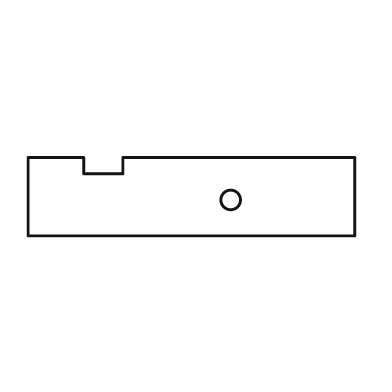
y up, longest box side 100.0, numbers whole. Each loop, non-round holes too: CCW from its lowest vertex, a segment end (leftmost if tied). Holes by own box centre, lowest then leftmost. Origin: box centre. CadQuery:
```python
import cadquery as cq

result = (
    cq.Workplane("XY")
    .moveTo(-50.0, -12.0)
    .lineTo(50.0, -12.0)
    .lineTo(50.0, 12.0)
    .lineTo(-21.0, 12.0)
    .lineTo(-21.0, 7.0)
    .lineTo(-33.0, 7.0)
    .lineTo(-33.0, 12.0)
    .lineTo(-50.0, 12.0)
    .close()
    .moveTo(12.0, -1.0)
    .circle(3.0)
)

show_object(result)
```